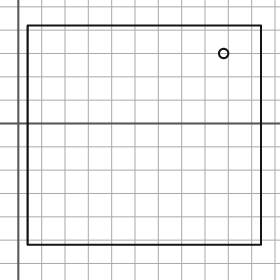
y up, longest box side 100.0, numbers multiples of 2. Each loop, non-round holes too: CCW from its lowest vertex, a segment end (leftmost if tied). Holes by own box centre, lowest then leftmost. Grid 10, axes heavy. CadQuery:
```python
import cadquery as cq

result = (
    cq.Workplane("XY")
    .moveTo(4.0, -52.0)
    .lineTo(104.0, -52.0)
    .lineTo(104.0, 42.0)
    .lineTo(4.0, 42.0)
    .close()
    .moveTo(88.0, 30.0)
    .circle(2.0)
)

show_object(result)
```